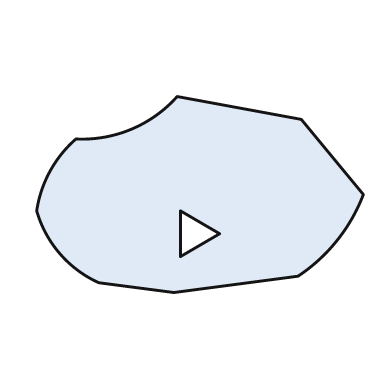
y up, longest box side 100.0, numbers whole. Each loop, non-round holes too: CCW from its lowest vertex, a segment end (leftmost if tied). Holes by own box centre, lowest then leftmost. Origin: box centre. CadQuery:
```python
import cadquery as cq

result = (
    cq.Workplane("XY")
    .moveTo(-8.0, -30.0)
    .lineTo(30.0, -25.0)
    .threePointArc((42.0, -14.0), (50.0, 0.0))
    .lineTo(31.0, 23.0)
    .lineTo(-7.0, 30.0)
    .threePointArc((-21.0, 20.0), (-38.0, 17.0))
    .threePointArc((-46.0, 7.0), (-50.0, -5.0))
    .threePointArc((-43.0, -18.0), (-31.0, -27.0))
    .close()
    .moveTo(-6.0, -19.0)
    .lineTo(6.0, -12.0)
    .lineTo(-6.0, -5.0)
    .close()
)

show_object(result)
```